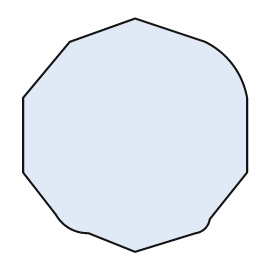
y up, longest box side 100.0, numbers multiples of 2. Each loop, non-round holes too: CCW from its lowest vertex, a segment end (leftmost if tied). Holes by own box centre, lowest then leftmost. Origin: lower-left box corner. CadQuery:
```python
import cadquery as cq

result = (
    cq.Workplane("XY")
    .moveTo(48.0, 0.0)
    .lineTo(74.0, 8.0)
    .threePointArc((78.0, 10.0), (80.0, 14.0))
    .lineTo(96.0, 34.0)
    .lineTo(96.0, 66.0)
    .threePointArc((90.0, 80.0), (78.0, 90.0))
    .lineTo(48.0, 100.0)
    .lineTo(20.0, 90.0)
    .lineTo(0.0, 66.0)
    .lineTo(0.0, 34.0)
    .lineTo(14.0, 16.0)
    .threePointArc((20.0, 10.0), (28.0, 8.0))
    .close()
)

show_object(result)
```